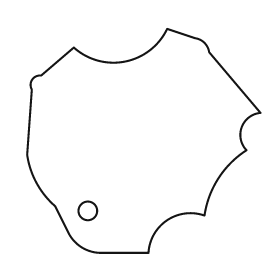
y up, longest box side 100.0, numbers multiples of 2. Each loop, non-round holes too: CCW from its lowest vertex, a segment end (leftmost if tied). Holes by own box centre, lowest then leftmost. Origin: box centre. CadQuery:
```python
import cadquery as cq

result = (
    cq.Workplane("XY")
    .moveTo(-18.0, -48.0)
    .lineTo(2.0, -48.0)
    .threePointArc((10.0, -34.0), (26.0, -32.0))
    .threePointArc((32.0, -16.0), (44.0, -4.0))
    .threePointArc((42.0, 6.0), (50.0, 12.0))
    .lineTo(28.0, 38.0)
    .threePointArc((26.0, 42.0), (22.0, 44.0))
    .lineTo(10.0, 48.0)
    .threePointArc((-8.0, 34.0), (-30.0, 40.0))
    .lineTo(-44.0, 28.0)
    .threePointArc((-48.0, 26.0), (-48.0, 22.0))
    .lineTo(-50.0, -6.0)
    .threePointArc((-46.0, -18.0), (-38.0, -28.0))
    .lineTo(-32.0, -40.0)
    .threePointArc((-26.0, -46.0), (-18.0, -48.0))
    .close()
    .moveTo(-24.0, -30.0)
    .circle(4.0)
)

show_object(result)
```